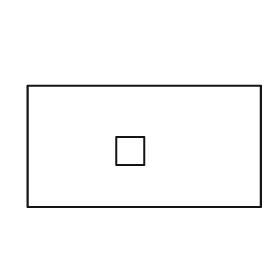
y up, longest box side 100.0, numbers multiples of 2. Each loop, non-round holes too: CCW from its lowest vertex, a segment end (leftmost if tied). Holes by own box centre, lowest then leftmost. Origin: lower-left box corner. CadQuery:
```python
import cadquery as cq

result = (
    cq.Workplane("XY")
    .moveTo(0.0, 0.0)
    .lineTo(100.0, 0.0)
    .lineTo(100.0, 52.0)
    .lineTo(0.0, 52.0)
    .close()
    .moveTo(38.0, 18.0)
    .lineTo(50.0, 18.0)
    .lineTo(50.0, 30.0)
    .lineTo(38.0, 30.0)
    .close()
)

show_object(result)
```